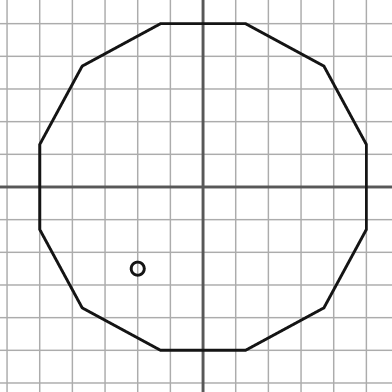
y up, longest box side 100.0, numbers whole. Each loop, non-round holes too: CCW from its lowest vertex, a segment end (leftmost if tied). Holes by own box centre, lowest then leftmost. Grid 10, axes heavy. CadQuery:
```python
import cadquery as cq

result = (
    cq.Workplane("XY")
    .moveTo(-13.0, -50.0)
    .lineTo(13.0, -50.0)
    .lineTo(37.0, -37.0)
    .lineTo(50.0, -13.0)
    .lineTo(50.0, 13.0)
    .lineTo(37.0, 37.0)
    .lineTo(13.0, 50.0)
    .lineTo(-13.0, 50.0)
    .lineTo(-37.0, 37.0)
    .lineTo(-50.0, 13.0)
    .lineTo(-50.0, -13.0)
    .lineTo(-37.0, -37.0)
    .close()
    .moveTo(-20.0, -25.0)
    .circle(2.0)
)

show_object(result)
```